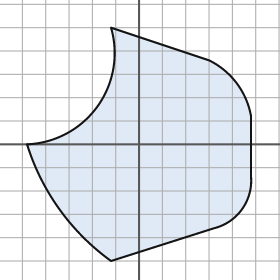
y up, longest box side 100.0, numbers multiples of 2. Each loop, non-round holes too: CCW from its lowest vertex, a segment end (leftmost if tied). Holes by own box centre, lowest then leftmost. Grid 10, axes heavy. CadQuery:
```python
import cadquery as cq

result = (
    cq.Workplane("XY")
    .moveTo(-12.0, -50.0)
    .lineTo(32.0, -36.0)
    .threePointArc((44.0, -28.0), (48.0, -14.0))
    .lineTo(48.0, 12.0)
    .threePointArc((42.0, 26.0), (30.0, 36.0))
    .lineTo(-12.0, 50.0)
    .threePointArc((-18.0, 16.0), (-48.0, 0.0))
    .threePointArc((-34.0, -28.0), (-12.0, -50.0))
    .close()
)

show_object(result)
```